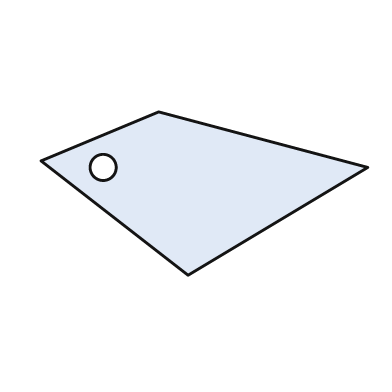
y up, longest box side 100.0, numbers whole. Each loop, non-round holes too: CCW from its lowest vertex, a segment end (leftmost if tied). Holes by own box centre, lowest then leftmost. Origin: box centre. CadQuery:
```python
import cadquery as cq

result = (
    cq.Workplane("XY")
    .moveTo(-5.0, -25.0)
    .lineTo(50.0, 8.0)
    .lineTo(-14.0, 25.0)
    .lineTo(-50.0, 10.0)
    .close()
    .moveTo(-31.0, 8.0)
    .circle(4.0)
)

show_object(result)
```